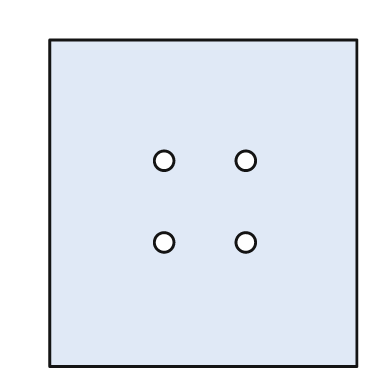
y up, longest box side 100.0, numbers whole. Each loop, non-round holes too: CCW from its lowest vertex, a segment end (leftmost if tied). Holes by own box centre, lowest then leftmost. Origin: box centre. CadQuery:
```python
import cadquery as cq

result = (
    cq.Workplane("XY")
    .moveTo(-47.0, -50.0)
    .lineTo(47.0, -50.0)
    .lineTo(47.0, 50.0)
    .lineTo(-47.0, 50.0)
    .close()
    .moveTo(-12.0, -12.0)
    .circle(3.0)
    .moveTo(13.0, -12.0)
    .circle(3.0)
    .moveTo(-12.0, 13.0)
    .circle(3.0)
    .moveTo(13.0, 13.0)
    .circle(3.0)
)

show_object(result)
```